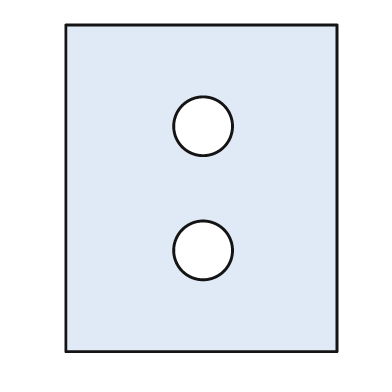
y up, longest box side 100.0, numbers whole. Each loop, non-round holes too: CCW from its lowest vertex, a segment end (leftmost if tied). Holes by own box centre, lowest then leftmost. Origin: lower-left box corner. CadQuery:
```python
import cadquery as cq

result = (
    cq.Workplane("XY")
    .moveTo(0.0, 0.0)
    .lineTo(83.0, 0.0)
    .lineTo(83.0, 100.0)
    .lineTo(0.0, 100.0)
    .close()
    .moveTo(42.0, 31.0)
    .circle(9.0)
    .moveTo(42.0, 69.0)
    .circle(9.0)
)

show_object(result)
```